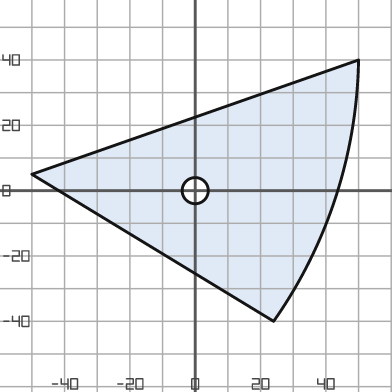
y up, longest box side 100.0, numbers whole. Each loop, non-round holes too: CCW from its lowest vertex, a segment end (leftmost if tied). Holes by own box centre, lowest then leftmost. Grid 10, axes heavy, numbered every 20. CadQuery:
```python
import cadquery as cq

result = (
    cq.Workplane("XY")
    .moveTo(24.0, -40.0)
    .threePointArc((43.0, -2.0), (50.0, 40.0))
    .lineTo(-50.0, 5.0)
    .close()
    .moveTo(0.0, 0.0)
    .circle(4.0)
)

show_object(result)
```